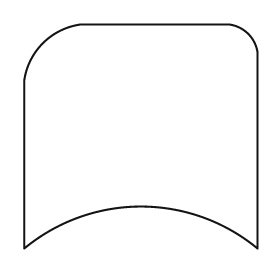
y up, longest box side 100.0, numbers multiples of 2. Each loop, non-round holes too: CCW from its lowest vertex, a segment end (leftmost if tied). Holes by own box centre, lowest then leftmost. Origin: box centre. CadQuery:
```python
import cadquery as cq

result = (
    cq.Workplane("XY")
    .moveTo(-50.0, -48.0)
    .threePointArc((0.0, -30.0), (50.0, -48.0))
    .lineTo(50.0, 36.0)
    .threePointArc((46.0, 44.0), (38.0, 48.0))
    .lineTo(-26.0, 48.0)
    .threePointArc((-42.0, 40.0), (-50.0, 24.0))
    .close()
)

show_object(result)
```